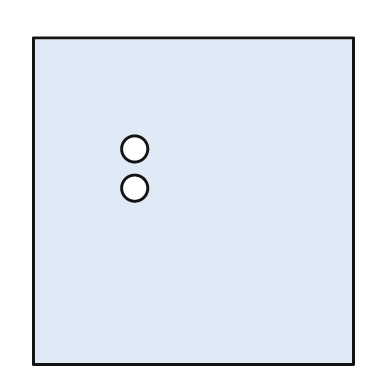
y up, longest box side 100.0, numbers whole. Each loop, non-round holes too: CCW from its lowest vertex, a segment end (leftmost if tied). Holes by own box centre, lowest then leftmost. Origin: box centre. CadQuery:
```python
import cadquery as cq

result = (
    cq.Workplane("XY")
    .moveTo(-49.0, -50.0)
    .lineTo(49.0, -50.0)
    .lineTo(49.0, 50.0)
    .lineTo(-49.0, 50.0)
    .close()
    .moveTo(-18.0, 4.0)
    .circle(4.0)
    .moveTo(-18.0, 16.0)
    .circle(4.0)
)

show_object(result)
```